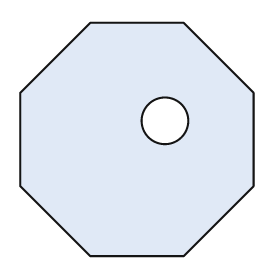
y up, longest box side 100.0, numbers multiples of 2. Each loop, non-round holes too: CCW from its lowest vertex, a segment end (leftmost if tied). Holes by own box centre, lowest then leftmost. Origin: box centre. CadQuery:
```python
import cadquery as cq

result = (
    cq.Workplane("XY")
    .moveTo(-20.0, -50.0)
    .lineTo(20.0, -50.0)
    .lineTo(50.0, -20.0)
    .lineTo(50.0, 20.0)
    .lineTo(20.0, 50.0)
    .lineTo(-20.0, 50.0)
    .lineTo(-50.0, 20.0)
    .lineTo(-50.0, -20.0)
    .close()
    .moveTo(12.0, 8.0)
    .circle(10.0)
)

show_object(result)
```